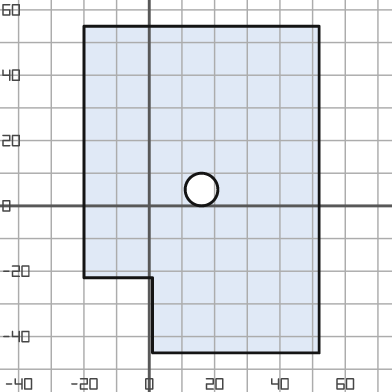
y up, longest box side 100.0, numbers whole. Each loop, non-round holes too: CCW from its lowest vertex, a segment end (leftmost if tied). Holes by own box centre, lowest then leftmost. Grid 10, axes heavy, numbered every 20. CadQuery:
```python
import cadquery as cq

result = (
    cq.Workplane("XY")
    .moveTo(1.0, -45.0)
    .lineTo(52.0, -45.0)
    .lineTo(52.0, 55.0)
    .lineTo(-20.0, 55.0)
    .lineTo(-20.0, -22.0)
    .lineTo(1.0, -22.0)
    .close()
    .moveTo(16.0, 5.0)
    .circle(5.0)
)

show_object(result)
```